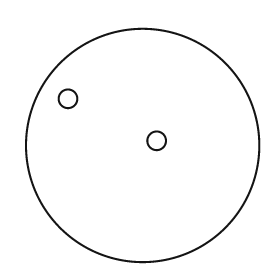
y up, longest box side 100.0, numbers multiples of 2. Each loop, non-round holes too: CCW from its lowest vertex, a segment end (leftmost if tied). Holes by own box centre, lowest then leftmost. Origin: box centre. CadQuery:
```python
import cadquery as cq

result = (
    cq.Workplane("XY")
    .moveTo(0.0, 0.0)
    .circle(50.0)
    .moveTo(6.0, 2.0)
    .circle(4.0)
    .moveTo(-32.0, 20.0)
    .circle(4.0)
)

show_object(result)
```